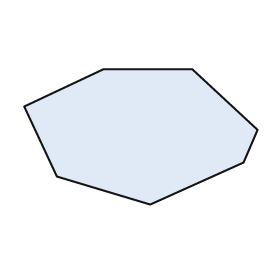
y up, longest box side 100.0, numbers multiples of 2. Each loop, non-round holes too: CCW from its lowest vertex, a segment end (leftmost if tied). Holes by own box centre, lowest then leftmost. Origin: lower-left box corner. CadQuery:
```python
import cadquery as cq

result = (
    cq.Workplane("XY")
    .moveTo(54.0, 0.0)
    .lineTo(94.0, 18.0)
    .lineTo(100.0, 32.0)
    .lineTo(72.0, 58.0)
    .lineTo(34.0, 58.0)
    .lineTo(0.0, 42.0)
    .lineTo(14.0, 12.0)
    .close()
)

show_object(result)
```